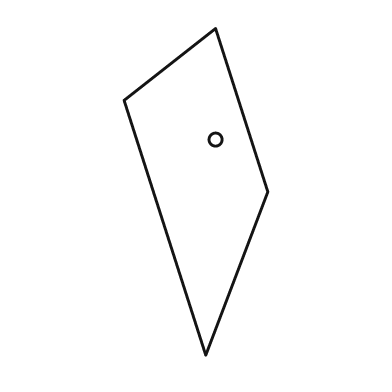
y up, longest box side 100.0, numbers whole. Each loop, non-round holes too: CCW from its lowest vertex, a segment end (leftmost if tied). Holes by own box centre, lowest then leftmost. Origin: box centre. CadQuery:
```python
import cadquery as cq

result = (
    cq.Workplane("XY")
    .moveTo(3.0, -50.0)
    .lineTo(22.0, 0.0)
    .lineTo(6.0, 50.0)
    .lineTo(-22.0, 28.0)
    .close()
    .moveTo(6.0, 16.0)
    .circle(2.0)
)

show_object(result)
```